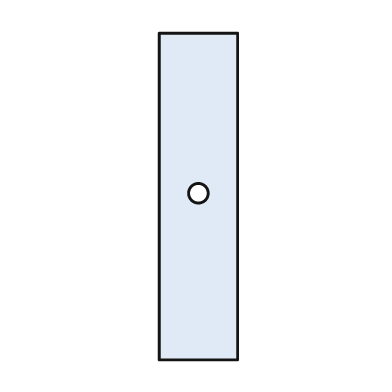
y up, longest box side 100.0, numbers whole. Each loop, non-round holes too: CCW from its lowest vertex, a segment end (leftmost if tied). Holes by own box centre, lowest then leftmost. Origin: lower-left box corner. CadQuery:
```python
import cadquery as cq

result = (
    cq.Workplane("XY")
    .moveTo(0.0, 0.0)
    .lineTo(24.0, 0.0)
    .lineTo(24.0, 100.0)
    .lineTo(0.0, 100.0)
    .close()
    .moveTo(12.0, 51.0)
    .circle(3.0)
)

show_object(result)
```